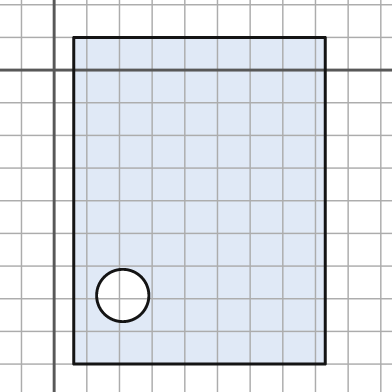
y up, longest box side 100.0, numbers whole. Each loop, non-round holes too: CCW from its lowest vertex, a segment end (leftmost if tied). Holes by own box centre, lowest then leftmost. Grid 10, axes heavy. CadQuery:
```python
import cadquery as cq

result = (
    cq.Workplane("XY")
    .moveTo(6.0, -90.0)
    .lineTo(83.0, -90.0)
    .lineTo(83.0, 10.0)
    .lineTo(6.0, 10.0)
    .close()
    .moveTo(21.0, -69.0)
    .circle(8.0)
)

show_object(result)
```